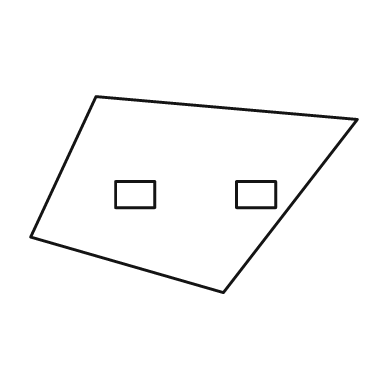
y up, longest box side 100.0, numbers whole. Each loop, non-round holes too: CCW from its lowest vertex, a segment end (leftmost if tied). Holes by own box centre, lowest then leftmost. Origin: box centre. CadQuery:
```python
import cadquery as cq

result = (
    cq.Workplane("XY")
    .moveTo(9.0, -30.0)
    .lineTo(50.0, 23.0)
    .lineTo(-30.0, 30.0)
    .lineTo(-50.0, -13.0)
    .close()
    .moveTo(-24.0, -4.0)
    .lineTo(-12.0, -4.0)
    .lineTo(-12.0, 4.0)
    .lineTo(-24.0, 4.0)
    .close()
    .moveTo(13.0, -4.0)
    .lineTo(25.0, -4.0)
    .lineTo(25.0, 4.0)
    .lineTo(13.0, 4.0)
    .close()
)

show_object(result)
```